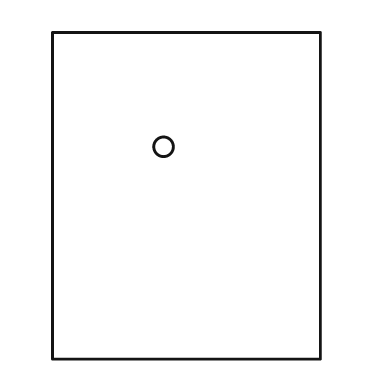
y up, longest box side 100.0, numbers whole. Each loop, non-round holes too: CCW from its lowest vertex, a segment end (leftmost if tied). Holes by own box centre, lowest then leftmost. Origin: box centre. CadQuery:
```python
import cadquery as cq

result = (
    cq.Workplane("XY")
    .moveTo(-41.0, -50.0)
    .lineTo(41.0, -50.0)
    .lineTo(41.0, 50.0)
    .lineTo(-41.0, 50.0)
    .close()
    .moveTo(-7.0, 15.0)
    .circle(3.0)
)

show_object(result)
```